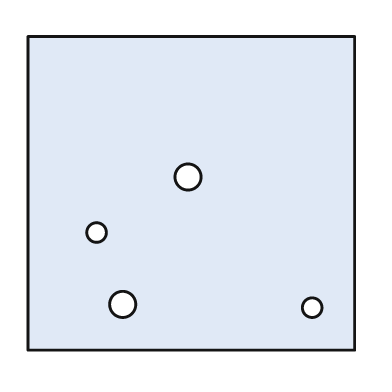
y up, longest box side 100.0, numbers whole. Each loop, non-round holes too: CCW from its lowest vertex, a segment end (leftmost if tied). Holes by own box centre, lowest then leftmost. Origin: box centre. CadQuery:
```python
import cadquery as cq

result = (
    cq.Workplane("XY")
    .moveTo(-50.0, -48.0)
    .lineTo(50.0, -48.0)
    .lineTo(50.0, 48.0)
    .lineTo(-50.0, 48.0)
    .close()
    .moveTo(37.0, -35.0)
    .circle(3.0)
    .moveTo(-21.0, -34.0)
    .circle(4.0)
    .moveTo(-29.0, -12.0)
    .circle(3.0)
    .moveTo(-1.0, 5.0)
    .circle(4.0)
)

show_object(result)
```